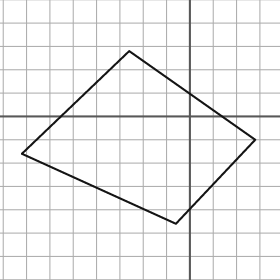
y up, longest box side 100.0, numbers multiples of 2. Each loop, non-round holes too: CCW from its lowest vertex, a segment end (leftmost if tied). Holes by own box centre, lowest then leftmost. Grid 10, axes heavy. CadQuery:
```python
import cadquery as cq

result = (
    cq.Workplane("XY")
    .moveTo(-6.0, -46.0)
    .lineTo(28.0, -10.0)
    .lineTo(-26.0, 28.0)
    .lineTo(-72.0, -16.0)
    .close()
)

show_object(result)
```